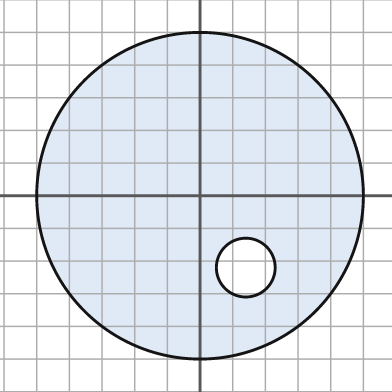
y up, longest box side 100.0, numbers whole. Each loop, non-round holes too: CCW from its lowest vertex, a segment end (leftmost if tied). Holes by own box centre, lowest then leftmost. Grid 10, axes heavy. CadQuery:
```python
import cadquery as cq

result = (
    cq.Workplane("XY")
    .moveTo(0.0, 0.0)
    .circle(50.0)
    .moveTo(14.0, -22.0)
    .circle(9.0)
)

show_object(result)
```